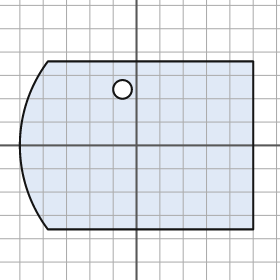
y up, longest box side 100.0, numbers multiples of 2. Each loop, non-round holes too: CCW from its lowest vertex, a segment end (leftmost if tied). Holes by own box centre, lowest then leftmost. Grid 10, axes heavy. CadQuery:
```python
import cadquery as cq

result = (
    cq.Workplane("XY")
    .moveTo(-38.0, -36.0)
    .lineTo(50.0, -36.0)
    .lineTo(50.0, 36.0)
    .lineTo(-38.0, 36.0)
    .threePointArc((-50.0, 0.0), (-38.0, -36.0))
    .close()
    .moveTo(-6.0, 24.0)
    .circle(4.0)
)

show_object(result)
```